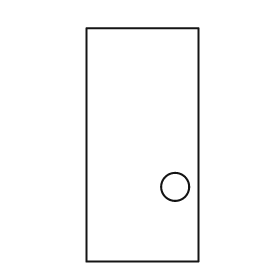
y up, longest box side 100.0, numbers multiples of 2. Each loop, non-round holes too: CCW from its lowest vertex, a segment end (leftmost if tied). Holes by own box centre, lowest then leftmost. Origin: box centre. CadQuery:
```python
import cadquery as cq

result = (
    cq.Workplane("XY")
    .moveTo(-24.0, -50.0)
    .lineTo(24.0, -50.0)
    .lineTo(24.0, 50.0)
    .lineTo(-24.0, 50.0)
    .close()
    .moveTo(14.0, -18.0)
    .circle(6.0)
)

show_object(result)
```